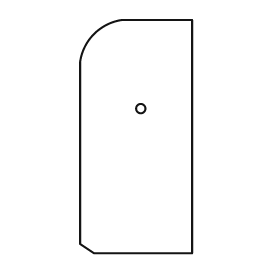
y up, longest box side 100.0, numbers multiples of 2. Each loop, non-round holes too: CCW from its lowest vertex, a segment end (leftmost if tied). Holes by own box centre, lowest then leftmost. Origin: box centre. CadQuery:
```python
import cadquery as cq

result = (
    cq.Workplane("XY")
    .moveTo(-18.0, -50.0)
    .lineTo(24.0, -50.0)
    .lineTo(24.0, 50.0)
    .lineTo(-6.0, 50.0)
    .threePointArc((-18.0, 44.0), (-24.0, 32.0))
    .lineTo(-24.0, -46.0)
    .close()
    .moveTo(2.0, 12.0)
    .circle(2.0)
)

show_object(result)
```